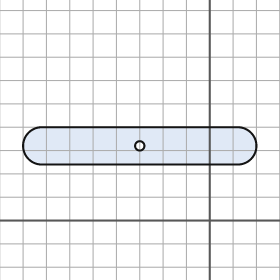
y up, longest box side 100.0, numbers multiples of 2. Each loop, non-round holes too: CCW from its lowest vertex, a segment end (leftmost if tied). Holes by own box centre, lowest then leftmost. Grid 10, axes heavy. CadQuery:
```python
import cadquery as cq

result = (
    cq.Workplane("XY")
    .moveTo(-72.0, 24.0)
    .lineTo(12.0, 24.0)
    .threePointArc((20.0, 32.0), (12.0, 40.0))
    .lineTo(-72.0, 40.0)
    .threePointArc((-80.0, 32.0), (-72.0, 24.0))
    .close()
    .moveTo(-30.0, 32.0)
    .circle(2.0)
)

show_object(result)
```